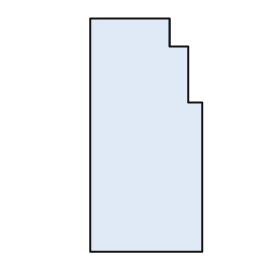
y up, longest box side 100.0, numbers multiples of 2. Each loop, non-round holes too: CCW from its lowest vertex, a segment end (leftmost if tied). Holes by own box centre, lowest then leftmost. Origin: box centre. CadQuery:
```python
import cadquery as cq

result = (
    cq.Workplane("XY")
    .moveTo(-24.0, -50.0)
    .lineTo(24.0, -50.0)
    .lineTo(24.0, 14.0)
    .lineTo(18.0, 14.0)
    .lineTo(18.0, 38.0)
    .lineTo(10.0, 38.0)
    .lineTo(10.0, 50.0)
    .lineTo(-24.0, 50.0)
    .close()
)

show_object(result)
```